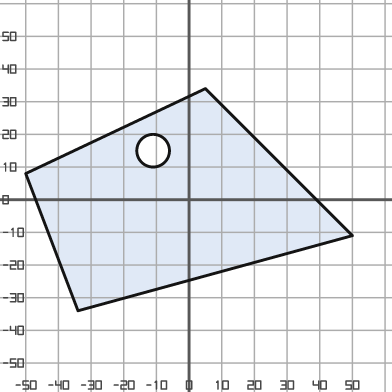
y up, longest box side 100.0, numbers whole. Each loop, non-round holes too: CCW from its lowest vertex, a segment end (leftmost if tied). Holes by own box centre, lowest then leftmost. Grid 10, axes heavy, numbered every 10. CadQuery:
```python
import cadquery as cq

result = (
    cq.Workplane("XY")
    .moveTo(-34.0, -34.0)
    .lineTo(50.0, -11.0)
    .lineTo(5.0, 34.0)
    .lineTo(-50.0, 8.0)
    .close()
    .moveTo(-11.0, 15.0)
    .circle(5.0)
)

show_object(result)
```